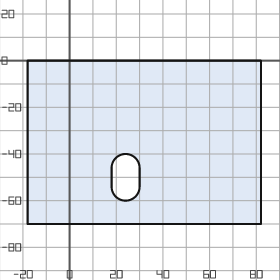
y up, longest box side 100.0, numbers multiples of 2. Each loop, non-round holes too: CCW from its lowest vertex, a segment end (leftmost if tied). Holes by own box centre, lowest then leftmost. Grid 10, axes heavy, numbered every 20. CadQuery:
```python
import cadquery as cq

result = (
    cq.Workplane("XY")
    .moveTo(-18.0, -70.0)
    .lineTo(82.0, -70.0)
    .lineTo(82.0, 0.0)
    .lineTo(-18.0, 0.0)
    .close()
    .moveTo(18.0, -54.0)
    .threePointArc((24.0, -60.0), (30.0, -54.0))
    .lineTo(30.0, -46.0)
    .threePointArc((24.0, -40.0), (18.0, -46.0))
    .close()
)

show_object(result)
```